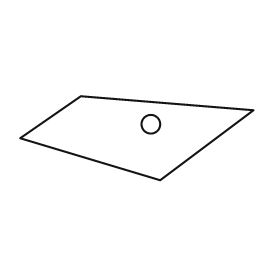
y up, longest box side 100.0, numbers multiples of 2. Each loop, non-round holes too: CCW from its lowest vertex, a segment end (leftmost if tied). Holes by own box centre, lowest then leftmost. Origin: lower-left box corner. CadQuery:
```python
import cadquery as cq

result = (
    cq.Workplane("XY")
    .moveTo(60.0, 0.0)
    .lineTo(100.0, 30.0)
    .lineTo(26.0, 36.0)
    .lineTo(0.0, 18.0)
    .close()
    .moveTo(56.0, 24.0)
    .circle(4.0)
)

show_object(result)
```